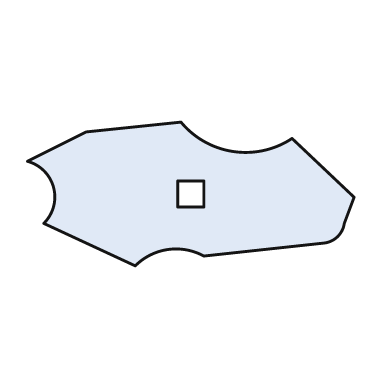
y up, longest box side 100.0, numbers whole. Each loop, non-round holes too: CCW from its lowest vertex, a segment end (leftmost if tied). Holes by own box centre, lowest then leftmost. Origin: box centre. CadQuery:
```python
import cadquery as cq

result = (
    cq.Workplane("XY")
    .moveTo(-17.0, -22.0)
    .threePointArc((-7.0, -17.0), (4.0, -19.0))
    .lineTo(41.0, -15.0)
    .threePointArc((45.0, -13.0), (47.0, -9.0))
    .lineTo(50.0, -1.0)
    .lineTo(31.0, 17.0)
    .threePointArc((13.0, 13.0), (-3.0, 22.0))
    .lineTo(-32.0, 19.0)
    .lineTo(-50.0, 10.0)
    .threePointArc((-42.0, 2.0), (-45.0, -9.0))
    .close()
    .moveTo(-4.0, -4.0)
    .lineTo(4.0, -4.0)
    .lineTo(4.0, 4.0)
    .lineTo(-4.0, 4.0)
    .close()
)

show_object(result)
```